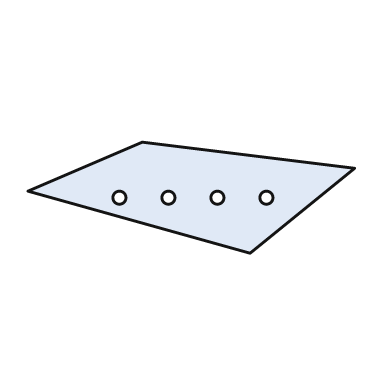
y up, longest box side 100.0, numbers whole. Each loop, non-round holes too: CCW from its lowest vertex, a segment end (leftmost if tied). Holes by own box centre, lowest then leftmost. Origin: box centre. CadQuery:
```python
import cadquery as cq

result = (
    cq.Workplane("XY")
    .moveTo(18.0, -17.0)
    .lineTo(50.0, 9.0)
    .lineTo(-15.0, 17.0)
    .lineTo(-50.0, 2.0)
    .close()
    .moveTo(-22.0, 0.0)
    .circle(2.0)
    .moveTo(-7.0, 0.0)
    .circle(2.0)
    .moveTo(8.0, 0.0)
    .circle(2.0)
    .moveTo(23.0, 0.0)
    .circle(2.0)
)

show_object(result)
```